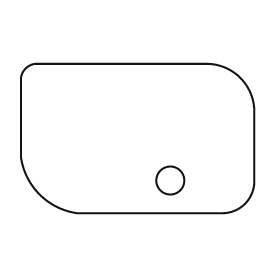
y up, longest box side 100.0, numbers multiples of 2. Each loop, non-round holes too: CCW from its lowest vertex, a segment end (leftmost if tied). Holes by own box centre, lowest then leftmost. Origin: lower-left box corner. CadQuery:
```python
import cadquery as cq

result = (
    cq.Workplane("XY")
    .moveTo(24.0, 0.0)
    .lineTo(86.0, 0.0)
    .threePointArc((96.0, 4.0), (100.0, 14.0))
    .lineTo(100.0, 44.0)
    .threePointArc((94.0, 58.0), (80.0, 64.0))
    .lineTo(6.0, 64.0)
    .threePointArc((2.0, 62.0), (0.0, 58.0))
    .lineTo(0.0, 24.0)
    .threePointArc((8.0, 8.0), (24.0, 0.0))
    .close()
    .moveTo(64.0, 14.0)
    .circle(6.0)
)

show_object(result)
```